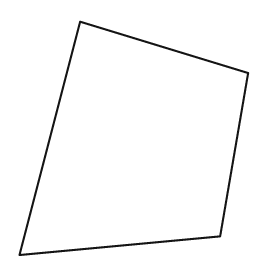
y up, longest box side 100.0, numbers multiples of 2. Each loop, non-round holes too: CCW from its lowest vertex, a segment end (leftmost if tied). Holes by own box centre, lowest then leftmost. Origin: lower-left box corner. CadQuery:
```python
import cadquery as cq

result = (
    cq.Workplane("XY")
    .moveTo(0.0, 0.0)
    .lineTo(86.0, 8.0)
    .lineTo(98.0, 78.0)
    .lineTo(26.0, 100.0)
    .close()
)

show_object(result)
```